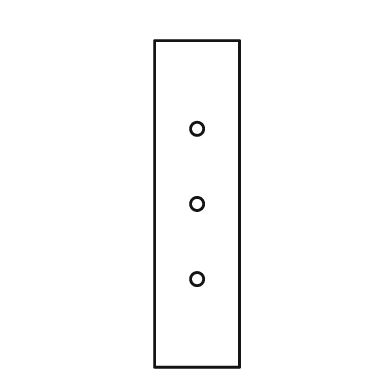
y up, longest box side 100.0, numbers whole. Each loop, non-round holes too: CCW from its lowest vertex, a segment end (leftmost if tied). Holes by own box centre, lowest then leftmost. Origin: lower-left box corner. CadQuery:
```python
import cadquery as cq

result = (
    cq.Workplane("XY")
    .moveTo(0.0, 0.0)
    .lineTo(26.0, 0.0)
    .lineTo(26.0, 100.0)
    .lineTo(0.0, 100.0)
    .close()
    .moveTo(13.0, 27.0)
    .circle(2.0)
    .moveTo(13.0, 50.0)
    .circle(2.0)
    .moveTo(13.0, 73.0)
    .circle(2.0)
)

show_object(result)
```